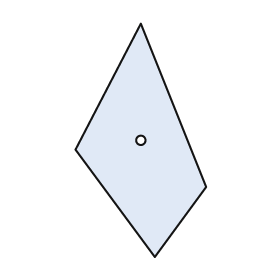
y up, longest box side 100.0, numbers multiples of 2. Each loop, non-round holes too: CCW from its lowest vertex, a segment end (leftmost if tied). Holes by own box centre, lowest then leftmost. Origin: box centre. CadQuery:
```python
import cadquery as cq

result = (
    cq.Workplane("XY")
    .moveTo(6.0, -50.0)
    .lineTo(28.0, -20.0)
    .lineTo(0.0, 50.0)
    .lineTo(-28.0, -4.0)
    .close()
    .moveTo(0.0, 0.0)
    .circle(2.0)
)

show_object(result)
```